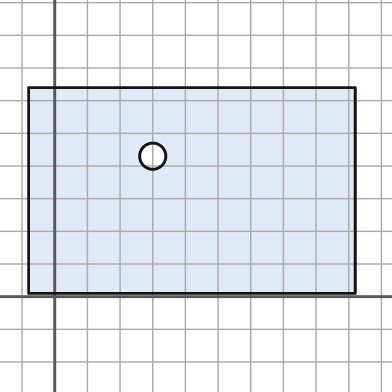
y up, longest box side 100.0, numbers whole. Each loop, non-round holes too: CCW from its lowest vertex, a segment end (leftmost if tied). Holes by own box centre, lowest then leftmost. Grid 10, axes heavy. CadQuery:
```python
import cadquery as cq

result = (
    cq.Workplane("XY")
    .moveTo(-8.0, 1.0)
    .lineTo(92.0, 1.0)
    .lineTo(92.0, 64.0)
    .lineTo(-8.0, 64.0)
    .close()
    .moveTo(30.0, 43.0)
    .circle(4.0)
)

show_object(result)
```